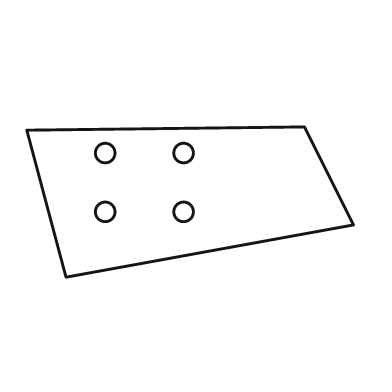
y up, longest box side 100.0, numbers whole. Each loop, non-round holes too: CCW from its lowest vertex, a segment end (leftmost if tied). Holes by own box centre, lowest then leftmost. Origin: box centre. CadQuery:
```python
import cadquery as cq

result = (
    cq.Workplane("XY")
    .moveTo(-38.0, -23.0)
    .lineTo(50.0, -7.0)
    .lineTo(35.0, 23.0)
    .lineTo(-50.0, 22.0)
    .close()
    .moveTo(-26.0, -3.0)
    .circle(3.0)
    .moveTo(-2.0, -3.0)
    .circle(3.0)
    .moveTo(-26.0, 15.0)
    .circle(3.0)
    .moveTo(-2.0, 15.0)
    .circle(3.0)
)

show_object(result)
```